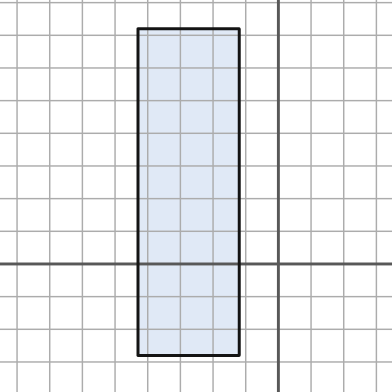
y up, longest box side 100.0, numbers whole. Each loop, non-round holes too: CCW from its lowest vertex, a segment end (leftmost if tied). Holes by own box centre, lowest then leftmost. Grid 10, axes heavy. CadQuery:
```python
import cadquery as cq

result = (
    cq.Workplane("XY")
    .moveTo(-43.0, -28.0)
    .lineTo(-12.0, -28.0)
    .lineTo(-12.0, 72.0)
    .lineTo(-43.0, 72.0)
    .close()
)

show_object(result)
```